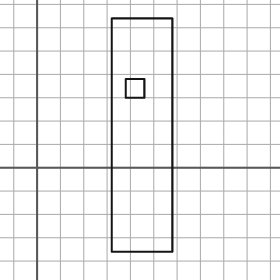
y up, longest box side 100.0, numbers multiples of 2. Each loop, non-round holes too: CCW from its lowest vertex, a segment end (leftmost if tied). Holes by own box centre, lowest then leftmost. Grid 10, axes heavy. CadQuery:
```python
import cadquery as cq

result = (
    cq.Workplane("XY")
    .moveTo(32.0, -36.0)
    .lineTo(58.0, -36.0)
    .lineTo(58.0, 64.0)
    .lineTo(32.0, 64.0)
    .close()
    .moveTo(38.0, 30.0)
    .lineTo(46.0, 30.0)
    .lineTo(46.0, 38.0)
    .lineTo(38.0, 38.0)
    .close()
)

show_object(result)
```